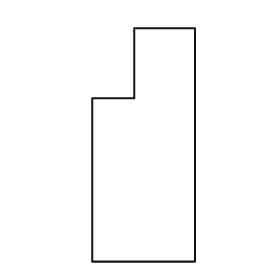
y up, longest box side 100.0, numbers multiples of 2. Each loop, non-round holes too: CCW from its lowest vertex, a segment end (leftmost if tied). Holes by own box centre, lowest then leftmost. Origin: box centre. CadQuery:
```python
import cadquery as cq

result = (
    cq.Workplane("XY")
    .moveTo(-22.0, -50.0)
    .lineTo(22.0, -50.0)
    .lineTo(22.0, 50.0)
    .lineTo(-4.0, 50.0)
    .lineTo(-4.0, 20.0)
    .lineTo(-22.0, 20.0)
    .close()
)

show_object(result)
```